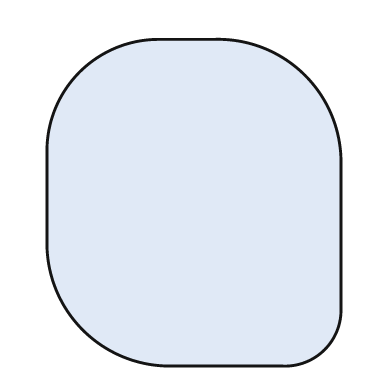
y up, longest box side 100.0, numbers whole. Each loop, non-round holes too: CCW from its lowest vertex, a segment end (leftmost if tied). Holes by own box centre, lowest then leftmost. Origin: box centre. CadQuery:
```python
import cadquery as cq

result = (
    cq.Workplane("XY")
    .moveTo(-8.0, -50.0)
    .lineTo(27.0, -50.0)
    .threePointArc((40.0, -45.0), (45.0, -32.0))
    .lineTo(45.0, 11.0)
    .threePointArc((34.0, 39.0), (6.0, 50.0))
    .lineTo(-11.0, 50.0)
    .threePointArc((-35.0, 40.0), (-45.0, 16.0))
    .lineTo(-45.0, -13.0)
    .threePointArc((-34.0, -39.0), (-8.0, -50.0))
    .close()
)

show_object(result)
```